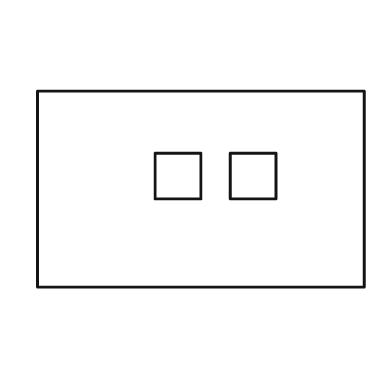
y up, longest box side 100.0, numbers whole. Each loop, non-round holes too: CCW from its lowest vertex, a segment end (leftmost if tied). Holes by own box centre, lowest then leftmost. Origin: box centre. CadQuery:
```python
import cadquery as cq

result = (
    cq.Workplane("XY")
    .moveTo(-50.0, -30.0)
    .lineTo(50.0, -30.0)
    .lineTo(50.0, 30.0)
    .lineTo(-50.0, 30.0)
    .close()
    .moveTo(-14.0, -3.0)
    .lineTo(0.0, -3.0)
    .lineTo(0.0, 11.0)
    .lineTo(-14.0, 11.0)
    .close()
    .moveTo(9.0, -3.0)
    .lineTo(23.0, -3.0)
    .lineTo(23.0, 11.0)
    .lineTo(9.0, 11.0)
    .close()
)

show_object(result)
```